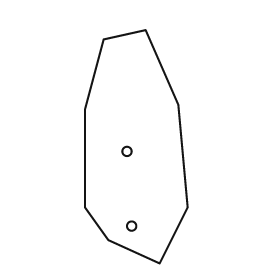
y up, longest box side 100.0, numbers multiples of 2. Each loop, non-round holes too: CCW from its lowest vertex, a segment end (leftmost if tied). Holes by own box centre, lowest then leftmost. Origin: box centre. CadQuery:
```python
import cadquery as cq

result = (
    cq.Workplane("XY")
    .moveTo(10.0, -50.0)
    .lineTo(22.0, -26.0)
    .lineTo(18.0, 18.0)
    .lineTo(4.0, 50.0)
    .lineTo(-14.0, 46.0)
    .lineTo(-22.0, 16.0)
    .lineTo(-22.0, -26.0)
    .lineTo(-12.0, -40.0)
    .close()
    .moveTo(-2.0, -34.0)
    .circle(2.0)
    .moveTo(-4.0, -2.0)
    .circle(2.0)
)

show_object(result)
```